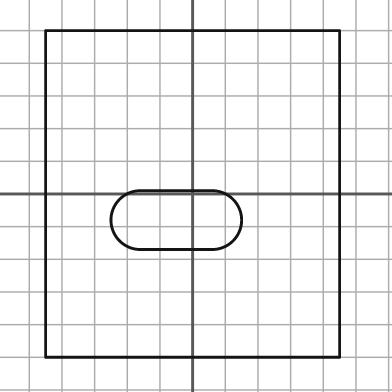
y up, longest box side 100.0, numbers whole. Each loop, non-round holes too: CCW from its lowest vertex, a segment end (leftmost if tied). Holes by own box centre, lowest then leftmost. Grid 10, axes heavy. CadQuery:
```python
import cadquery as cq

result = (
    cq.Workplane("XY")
    .moveTo(-45.0, -50.0)
    .lineTo(45.0, -50.0)
    .lineTo(45.0, 50.0)
    .lineTo(-45.0, 50.0)
    .close()
    .moveTo(-16.0, -17.0)
    .lineTo(6.0, -17.0)
    .threePointArc((15.0, -8.0), (6.0, 1.0))
    .lineTo(-16.0, 1.0)
    .threePointArc((-25.0, -8.0), (-16.0, -17.0))
    .close()
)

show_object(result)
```